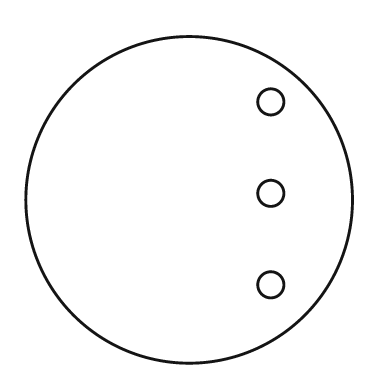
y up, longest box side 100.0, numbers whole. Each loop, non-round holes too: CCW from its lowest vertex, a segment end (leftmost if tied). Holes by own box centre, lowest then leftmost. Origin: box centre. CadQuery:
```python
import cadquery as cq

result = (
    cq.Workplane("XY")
    .moveTo(0.0, 0.0)
    .circle(50.0)
    .moveTo(25.0, -26.0)
    .circle(4.0)
    .moveTo(25.0, 2.0)
    .circle(4.0)
    .moveTo(25.0, 30.0)
    .circle(4.0)
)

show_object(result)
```